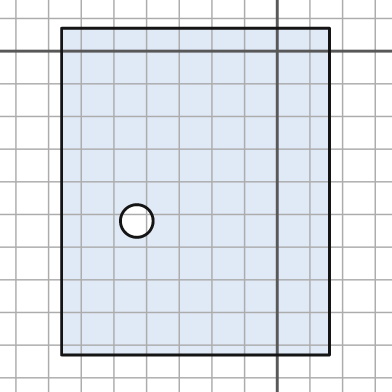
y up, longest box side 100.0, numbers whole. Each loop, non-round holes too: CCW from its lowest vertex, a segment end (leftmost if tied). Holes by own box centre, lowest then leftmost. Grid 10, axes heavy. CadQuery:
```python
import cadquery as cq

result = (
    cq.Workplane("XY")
    .moveTo(-66.0, -93.0)
    .lineTo(16.0, -93.0)
    .lineTo(16.0, 7.0)
    .lineTo(-66.0, 7.0)
    .close()
    .moveTo(-43.0, -52.0)
    .circle(5.0)
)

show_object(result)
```